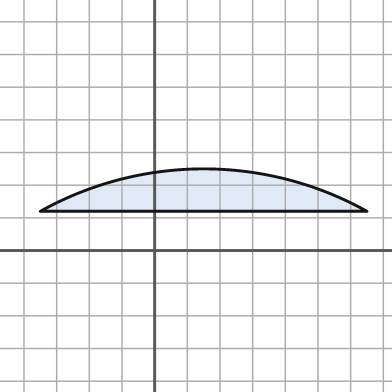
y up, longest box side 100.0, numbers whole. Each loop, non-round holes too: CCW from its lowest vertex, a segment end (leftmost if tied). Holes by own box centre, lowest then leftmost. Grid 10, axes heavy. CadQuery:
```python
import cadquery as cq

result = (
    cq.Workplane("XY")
    .moveTo(-35.0, 12.0)
    .lineTo(65.0, 12.0)
    .threePointArc((15.0, 25.0), (-35.0, 12.0))
    .close()
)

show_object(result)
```